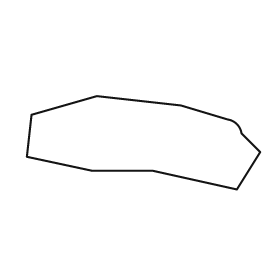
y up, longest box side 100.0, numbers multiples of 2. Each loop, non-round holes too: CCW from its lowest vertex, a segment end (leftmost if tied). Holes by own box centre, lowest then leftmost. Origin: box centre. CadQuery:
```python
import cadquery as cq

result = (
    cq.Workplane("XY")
    .moveTo(40.0, -20.0)
    .lineTo(50.0, -4.0)
    .lineTo(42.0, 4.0)
    .threePointArc((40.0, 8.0), (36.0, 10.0))
    .lineTo(16.0, 16.0)
    .lineTo(-20.0, 20.0)
    .lineTo(-48.0, 12.0)
    .lineTo(-50.0, -6.0)
    .lineTo(-22.0, -12.0)
    .lineTo(4.0, -12.0)
    .close()
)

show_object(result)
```